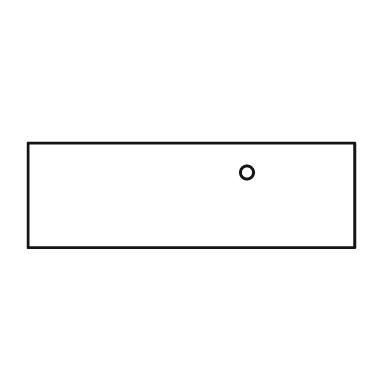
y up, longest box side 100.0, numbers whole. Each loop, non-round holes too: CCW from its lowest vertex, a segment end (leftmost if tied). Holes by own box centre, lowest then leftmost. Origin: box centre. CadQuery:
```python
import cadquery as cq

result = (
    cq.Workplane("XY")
    .moveTo(-50.0, -16.0)
    .lineTo(50.0, -16.0)
    .lineTo(50.0, 16.0)
    .lineTo(-50.0, 16.0)
    .close()
    .moveTo(17.0, 7.0)
    .circle(2.0)
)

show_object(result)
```